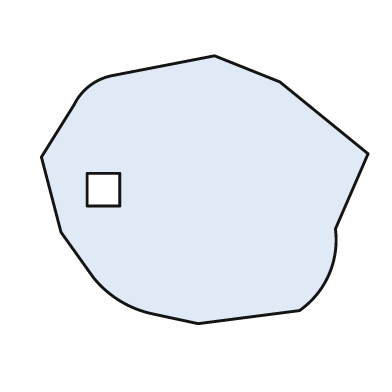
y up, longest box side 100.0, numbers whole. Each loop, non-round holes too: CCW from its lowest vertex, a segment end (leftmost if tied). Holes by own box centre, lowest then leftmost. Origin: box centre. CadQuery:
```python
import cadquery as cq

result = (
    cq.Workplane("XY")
    .moveTo(-2.0, -41.0)
    .lineTo(29.0, -37.0)
    .threePointArc((38.0, -26.0), (40.0, -12.0))
    .lineTo(50.0, 11.0)
    .lineTo(23.0, 33.0)
    .lineTo(3.0, 41.0)
    .lineTo(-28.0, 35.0)
    .threePointArc((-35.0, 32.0), (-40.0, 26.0))
    .lineTo(-50.0, 10.0)
    .lineTo(-44.0, -13.0)
    .lineTo(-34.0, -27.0)
    .threePointArc((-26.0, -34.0), (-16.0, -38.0))
    .close()
    .moveTo(-36.0, -5.0)
    .lineTo(-26.0, -5.0)
    .lineTo(-26.0, 5.0)
    .lineTo(-36.0, 5.0)
    .close()
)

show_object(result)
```